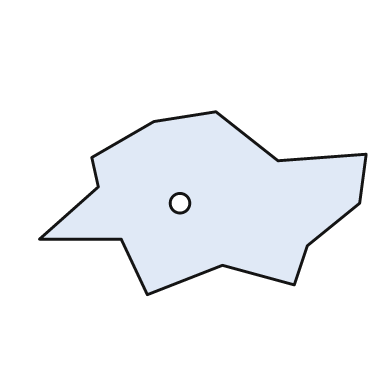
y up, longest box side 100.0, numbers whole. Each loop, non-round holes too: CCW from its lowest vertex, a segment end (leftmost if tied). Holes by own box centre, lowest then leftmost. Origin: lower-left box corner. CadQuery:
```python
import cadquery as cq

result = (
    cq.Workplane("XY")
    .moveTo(33.0, 0.0)
    .lineTo(56.0, 9.0)
    .lineTo(78.0, 3.0)
    .lineTo(82.0, 15.0)
    .lineTo(98.0, 28.0)
    .lineTo(100.0, 43.0)
    .lineTo(73.0, 41.0)
    .lineTo(54.0, 56.0)
    .lineTo(35.0, 53.0)
    .lineTo(16.0, 42.0)
    .lineTo(18.0, 33.0)
    .lineTo(0.0, 17.0)
    .lineTo(25.0, 17.0)
    .close()
    .moveTo(43.0, 28.0)
    .circle(3.0)
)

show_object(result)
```